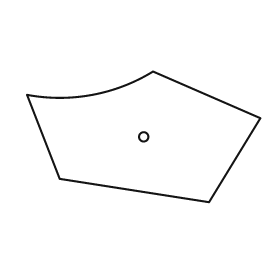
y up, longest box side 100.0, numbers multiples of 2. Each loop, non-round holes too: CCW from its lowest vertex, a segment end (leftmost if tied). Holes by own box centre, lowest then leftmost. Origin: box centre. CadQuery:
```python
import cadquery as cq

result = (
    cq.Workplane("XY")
    .moveTo(28.0, -28.0)
    .lineTo(50.0, 8.0)
    .lineTo(4.0, 28.0)
    .threePointArc((-22.0, 18.0), (-50.0, 18.0))
    .lineTo(-36.0, -18.0)
    .close()
    .moveTo(0.0, 0.0)
    .circle(2.0)
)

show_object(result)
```